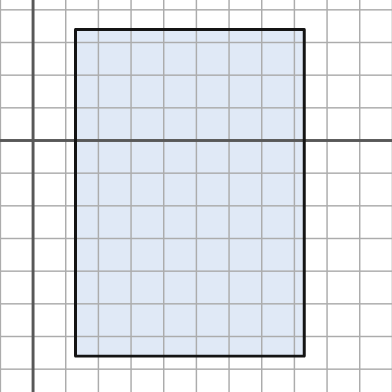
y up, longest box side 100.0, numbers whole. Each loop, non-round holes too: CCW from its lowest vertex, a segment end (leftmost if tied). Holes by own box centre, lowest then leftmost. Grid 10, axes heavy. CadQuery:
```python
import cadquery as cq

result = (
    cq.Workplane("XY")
    .moveTo(13.0, -66.0)
    .lineTo(83.0, -66.0)
    .lineTo(83.0, 34.0)
    .lineTo(13.0, 34.0)
    .close()
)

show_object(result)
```